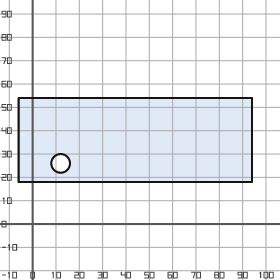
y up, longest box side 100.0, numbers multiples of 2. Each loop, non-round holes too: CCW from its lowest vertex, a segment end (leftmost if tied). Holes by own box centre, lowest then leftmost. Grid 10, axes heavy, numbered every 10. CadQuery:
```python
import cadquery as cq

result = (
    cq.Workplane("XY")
    .moveTo(-6.0, 18.0)
    .lineTo(94.0, 18.0)
    .lineTo(94.0, 54.0)
    .lineTo(-6.0, 54.0)
    .close()
    .moveTo(12.0, 26.0)
    .circle(4.0)
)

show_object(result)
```